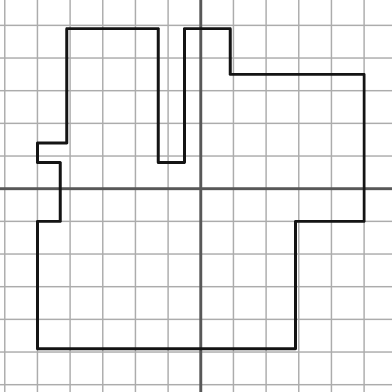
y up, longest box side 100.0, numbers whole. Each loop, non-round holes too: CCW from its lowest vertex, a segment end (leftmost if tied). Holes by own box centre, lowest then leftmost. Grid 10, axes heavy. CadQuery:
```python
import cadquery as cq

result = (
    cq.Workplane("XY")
    .moveTo(-50.0, -49.0)
    .lineTo(29.0, -49.0)
    .lineTo(29.0, -10.0)
    .lineTo(50.0, -10.0)
    .lineTo(50.0, 35.0)
    .lineTo(9.0, 35.0)
    .lineTo(9.0, 49.0)
    .lineTo(-5.0, 49.0)
    .lineTo(-5.0, 8.0)
    .lineTo(-13.0, 8.0)
    .lineTo(-13.0, 49.0)
    .lineTo(-41.0, 49.0)
    .lineTo(-41.0, 14.0)
    .lineTo(-50.0, 14.0)
    .lineTo(-50.0, 8.0)
    .lineTo(-43.0, 8.0)
    .lineTo(-43.0, -10.0)
    .lineTo(-50.0, -10.0)
    .close()
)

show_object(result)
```